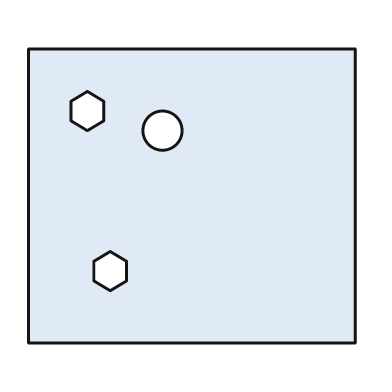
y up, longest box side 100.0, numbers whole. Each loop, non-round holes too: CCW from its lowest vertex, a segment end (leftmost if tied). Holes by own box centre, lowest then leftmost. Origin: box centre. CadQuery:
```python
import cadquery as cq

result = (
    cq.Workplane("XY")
    .moveTo(-50.0, -45.0)
    .lineTo(50.0, -45.0)
    .lineTo(50.0, 45.0)
    .lineTo(-50.0, 45.0)
    .close()
    .moveTo(-25.0, -29.0)
    .lineTo(-20.0, -26.0)
    .lineTo(-20.0, -20.0)
    .lineTo(-25.0, -17.0)
    .lineTo(-30.0, -20.0)
    .lineTo(-30.0, -26.0)
    .close()
    .moveTo(-9.0, 20.0)
    .circle(6.0)
    .moveTo(-32.0, 20.0)
    .lineTo(-27.0, 23.0)
    .lineTo(-27.0, 29.0)
    .lineTo(-32.0, 32.0)
    .lineTo(-37.0, 29.0)
    .lineTo(-37.0, 23.0)
    .close()
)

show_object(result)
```